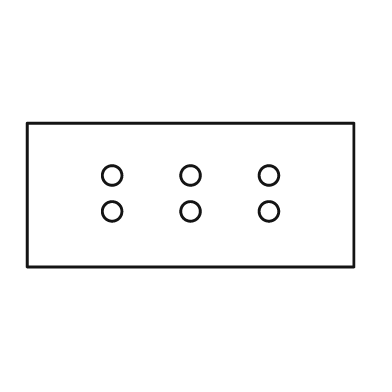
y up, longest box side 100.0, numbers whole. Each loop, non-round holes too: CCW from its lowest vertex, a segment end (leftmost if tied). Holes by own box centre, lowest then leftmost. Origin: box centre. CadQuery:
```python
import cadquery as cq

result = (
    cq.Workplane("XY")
    .moveTo(-50.0, -22.0)
    .lineTo(50.0, -22.0)
    .lineTo(50.0, 22.0)
    .lineTo(-50.0, 22.0)
    .close()
    .moveTo(-24.0, -5.0)
    .circle(3.0)
    .moveTo(0.0, -5.0)
    .circle(3.0)
    .moveTo(24.0, -5.0)
    .circle(3.0)
    .moveTo(-24.0, 6.0)
    .circle(3.0)
    .moveTo(0.0, 6.0)
    .circle(3.0)
    .moveTo(24.0, 6.0)
    .circle(3.0)
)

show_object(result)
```